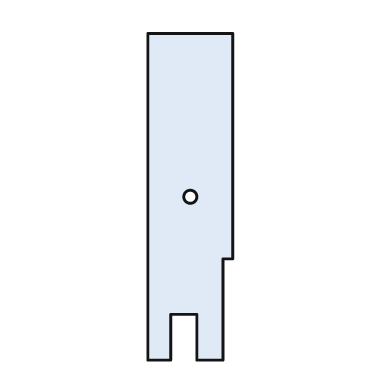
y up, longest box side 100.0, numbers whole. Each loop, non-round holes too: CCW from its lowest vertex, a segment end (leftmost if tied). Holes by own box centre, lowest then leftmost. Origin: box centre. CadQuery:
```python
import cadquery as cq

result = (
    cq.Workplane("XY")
    .moveTo(-13.0, -50.0)
    .lineTo(-6.0, -50.0)
    .lineTo(-6.0, -36.0)
    .lineTo(2.0, -36.0)
    .lineTo(2.0, -50.0)
    .lineTo(10.0, -50.0)
    .lineTo(10.0, -19.0)
    .lineTo(13.0, -19.0)
    .lineTo(13.0, 50.0)
    .lineTo(-13.0, 50.0)
    .close()
    .moveTo(0.0, 0.0)
    .circle(2.0)
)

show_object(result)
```